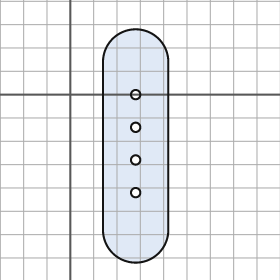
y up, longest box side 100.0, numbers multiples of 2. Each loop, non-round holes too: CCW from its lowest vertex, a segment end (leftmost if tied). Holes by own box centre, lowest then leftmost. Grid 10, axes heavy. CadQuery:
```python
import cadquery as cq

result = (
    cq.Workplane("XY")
    .moveTo(14.0, -58.0)
    .threePointArc((28.0, -72.0), (42.0, -58.0))
    .lineTo(42.0, 14.0)
    .threePointArc((28.0, 28.0), (14.0, 14.0))
    .close()
    .moveTo(28.0, -42.0)
    .circle(2.0)
    .moveTo(28.0, -28.0)
    .circle(2.0)
    .moveTo(28.0, -14.0)
    .circle(2.0)
    .moveTo(28.0, 0.0)
    .circle(2.0)
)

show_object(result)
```